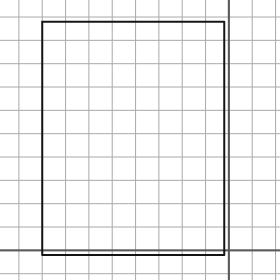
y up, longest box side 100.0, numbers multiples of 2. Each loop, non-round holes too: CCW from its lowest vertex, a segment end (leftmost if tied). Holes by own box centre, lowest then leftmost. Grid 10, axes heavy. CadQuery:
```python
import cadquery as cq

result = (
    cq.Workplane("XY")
    .moveTo(-80.0, -2.0)
    .lineTo(-2.0, -2.0)
    .lineTo(-2.0, 98.0)
    .lineTo(-80.0, 98.0)
    .close()
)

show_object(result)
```